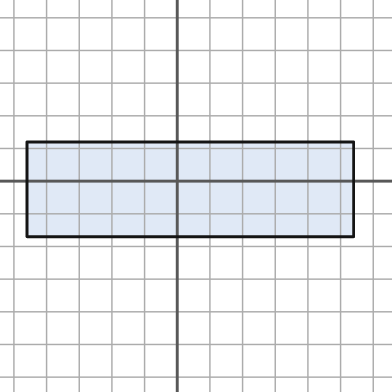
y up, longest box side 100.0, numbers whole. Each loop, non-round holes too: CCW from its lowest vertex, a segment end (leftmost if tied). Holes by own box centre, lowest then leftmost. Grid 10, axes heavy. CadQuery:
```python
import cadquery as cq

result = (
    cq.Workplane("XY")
    .moveTo(-46.0, -17.0)
    .lineTo(54.0, -17.0)
    .lineTo(54.0, 12.0)
    .lineTo(-46.0, 12.0)
    .close()
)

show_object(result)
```